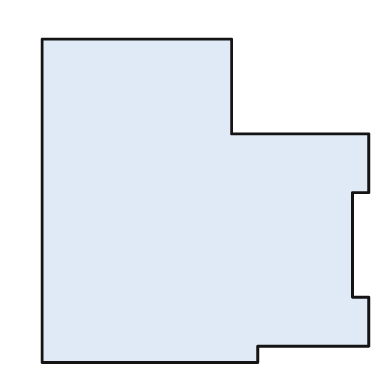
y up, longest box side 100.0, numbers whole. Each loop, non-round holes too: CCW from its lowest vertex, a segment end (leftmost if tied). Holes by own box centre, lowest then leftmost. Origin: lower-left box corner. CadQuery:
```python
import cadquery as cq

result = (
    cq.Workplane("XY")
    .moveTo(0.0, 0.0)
    .lineTo(66.0, 0.0)
    .lineTo(66.0, 5.0)
    .lineTo(100.0, 5.0)
    .lineTo(100.0, 20.0)
    .lineTo(95.0, 20.0)
    .lineTo(95.0, 52.0)
    .lineTo(100.0, 52.0)
    .lineTo(100.0, 70.0)
    .lineTo(58.0, 70.0)
    .lineTo(58.0, 99.0)
    .lineTo(0.0, 99.0)
    .close()
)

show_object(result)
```